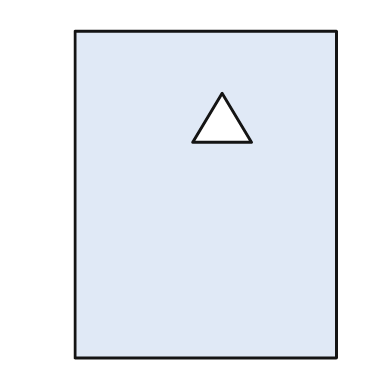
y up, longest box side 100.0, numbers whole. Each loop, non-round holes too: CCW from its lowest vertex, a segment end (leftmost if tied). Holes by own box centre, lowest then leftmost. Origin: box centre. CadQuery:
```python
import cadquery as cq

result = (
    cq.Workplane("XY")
    .moveTo(-40.0, -50.0)
    .lineTo(40.0, -50.0)
    .lineTo(40.0, 50.0)
    .lineTo(-40.0, 50.0)
    .close()
    .moveTo(-4.0, 16.0)
    .lineTo(14.0, 16.0)
    .lineTo(5.0, 31.0)
    .close()
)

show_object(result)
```